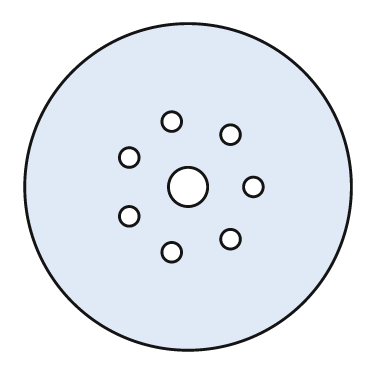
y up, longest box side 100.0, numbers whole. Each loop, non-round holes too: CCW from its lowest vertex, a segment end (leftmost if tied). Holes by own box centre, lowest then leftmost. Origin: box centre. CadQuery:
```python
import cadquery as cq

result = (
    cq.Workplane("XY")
    .moveTo(0.0, 0.0)
    .circle(50.0)
    .moveTo(-5.0, -20.0)
    .circle(3.0)
    .moveTo(13.0, -16.0)
    .circle(3.0)
    .moveTo(-18.0, -9.0)
    .circle(3.0)
    .moveTo(0.0, 0.0)
    .circle(6.0)
    .moveTo(20.0, 0.0)
    .circle(3.0)
    .moveTo(-18.0, 9.0)
    .circle(3.0)
    .moveTo(13.0, 16.0)
    .circle(3.0)
    .moveTo(-5.0, 20.0)
    .circle(3.0)
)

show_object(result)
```